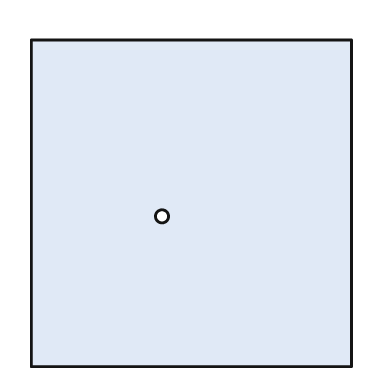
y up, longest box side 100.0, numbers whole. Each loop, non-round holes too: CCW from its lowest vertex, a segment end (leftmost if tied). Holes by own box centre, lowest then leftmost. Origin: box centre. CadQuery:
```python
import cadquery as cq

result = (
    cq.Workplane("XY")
    .moveTo(-49.0, -50.0)
    .lineTo(49.0, -50.0)
    .lineTo(49.0, 50.0)
    .lineTo(-49.0, 50.0)
    .close()
    .moveTo(-9.0, -4.0)
    .circle(2.0)
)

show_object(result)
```